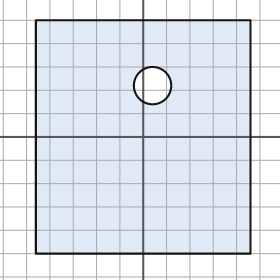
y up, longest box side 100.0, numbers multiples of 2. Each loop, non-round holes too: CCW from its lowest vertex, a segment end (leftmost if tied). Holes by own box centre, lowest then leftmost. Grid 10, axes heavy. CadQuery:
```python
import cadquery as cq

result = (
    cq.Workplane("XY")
    .moveTo(-46.0, -50.0)
    .lineTo(46.0, -50.0)
    .lineTo(46.0, 50.0)
    .lineTo(-46.0, 50.0)
    .close()
    .moveTo(4.0, 22.0)
    .circle(8.0)
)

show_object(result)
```